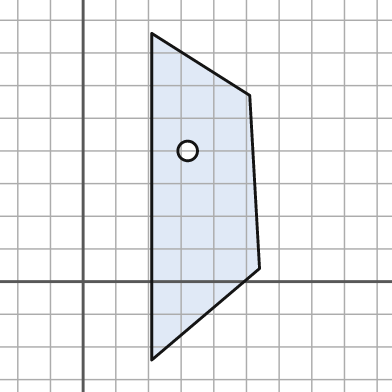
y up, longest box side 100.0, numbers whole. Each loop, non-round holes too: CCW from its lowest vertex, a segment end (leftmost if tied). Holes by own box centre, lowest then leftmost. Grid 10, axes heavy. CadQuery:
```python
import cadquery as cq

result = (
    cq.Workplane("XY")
    .moveTo(21.0, -24.0)
    .lineTo(54.0, 4.0)
    .lineTo(51.0, 57.0)
    .lineTo(21.0, 76.0)
    .close()
    .moveTo(32.0, 40.0)
    .circle(3.0)
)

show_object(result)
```